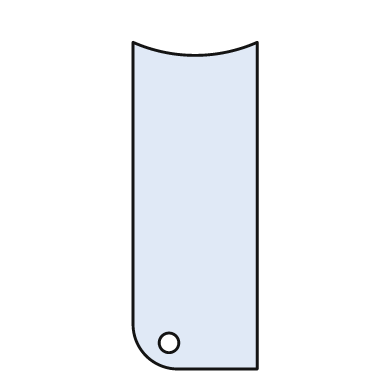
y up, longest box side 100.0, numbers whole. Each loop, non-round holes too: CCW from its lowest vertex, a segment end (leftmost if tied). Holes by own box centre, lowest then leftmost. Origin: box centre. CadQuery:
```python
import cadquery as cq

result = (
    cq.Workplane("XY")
    .moveTo(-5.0, -50.0)
    .lineTo(19.0, -50.0)
    .lineTo(19.0, 50.0)
    .threePointArc((0.0, 46.0), (-19.0, 50.0))
    .lineTo(-19.0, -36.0)
    .threePointArc((-15.0, -46.0), (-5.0, -50.0))
    .close()
    .moveTo(-8.0, -42.0)
    .circle(3.0)
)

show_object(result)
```